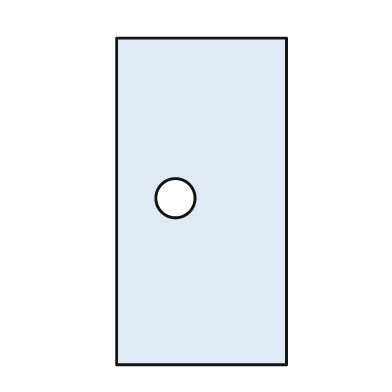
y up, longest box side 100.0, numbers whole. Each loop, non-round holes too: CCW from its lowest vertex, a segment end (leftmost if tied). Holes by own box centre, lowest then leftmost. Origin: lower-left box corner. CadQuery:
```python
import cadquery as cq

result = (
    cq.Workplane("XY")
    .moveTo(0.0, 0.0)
    .lineTo(52.0, 0.0)
    .lineTo(52.0, 100.0)
    .lineTo(0.0, 100.0)
    .close()
    .moveTo(18.0, 51.0)
    .circle(6.0)
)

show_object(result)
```